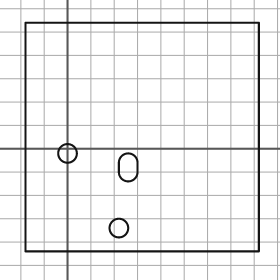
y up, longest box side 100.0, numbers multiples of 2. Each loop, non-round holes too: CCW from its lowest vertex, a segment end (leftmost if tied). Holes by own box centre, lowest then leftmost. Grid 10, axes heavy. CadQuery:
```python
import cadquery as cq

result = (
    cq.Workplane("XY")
    .moveTo(-18.0, -44.0)
    .lineTo(82.0, -44.0)
    .lineTo(82.0, 54.0)
    .lineTo(-18.0, 54.0)
    .close()
    .moveTo(22.0, -34.0)
    .circle(4.0)
    .moveTo(22.0, -10.0)
    .threePointArc((26.0, -14.0), (30.0, -10.0))
    .lineTo(30.0, -6.0)
    .threePointArc((26.0, -2.0), (22.0, -6.0))
    .close()
    .moveTo(0.0, -2.0)
    .circle(4.0)
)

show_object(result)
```